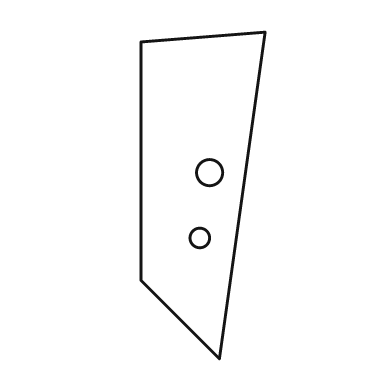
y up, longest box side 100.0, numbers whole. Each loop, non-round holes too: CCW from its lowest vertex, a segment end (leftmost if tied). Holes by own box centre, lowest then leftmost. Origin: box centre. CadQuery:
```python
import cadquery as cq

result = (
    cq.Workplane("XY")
    .moveTo(5.0, -50.0)
    .lineTo(19.0, 50.0)
    .lineTo(-19.0, 47.0)
    .lineTo(-19.0, -26.0)
    .close()
    .moveTo(-1.0, -13.0)
    .circle(3.0)
    .moveTo(2.0, 7.0)
    .circle(4.0)
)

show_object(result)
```